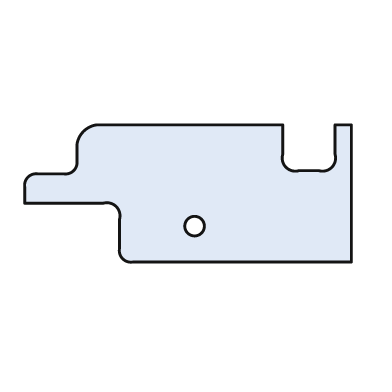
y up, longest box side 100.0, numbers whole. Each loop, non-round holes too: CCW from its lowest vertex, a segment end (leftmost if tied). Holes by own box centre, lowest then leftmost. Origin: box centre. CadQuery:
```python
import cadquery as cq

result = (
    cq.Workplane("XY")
    .moveTo(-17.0, -21.0)
    .lineTo(50.0, -21.0)
    .lineTo(50.0, 21.0)
    .lineTo(45.0, 21.0)
    .lineTo(45.0, 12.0)
    .threePointArc((44.0, 8.0), (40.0, 7.0))
    .lineTo(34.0, 7.0)
    .threePointArc((30.0, 8.0), (29.0, 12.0))
    .lineTo(29.0, 21.0)
    .lineTo(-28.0, 21.0)
    .threePointArc((-32.0, 19.0), (-34.0, 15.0))
    .lineTo(-34.0, 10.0)
    .threePointArc((-35.0, 7.0), (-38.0, 6.0))
    .lineTo(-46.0, 6.0)
    .threePointArc((-49.0, 5.0), (-50.0, 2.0))
    .lineTo(-50.0, -3.0)
    .lineTo(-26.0, -3.0)
    .threePointArc((-22.0, -4.0), (-21.0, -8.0))
    .lineTo(-21.0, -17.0)
    .threePointArc((-20.0, -20.0), (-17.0, -21.0))
    .close()
    .moveTo(2.0, -10.0)
    .circle(3.0)
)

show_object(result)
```